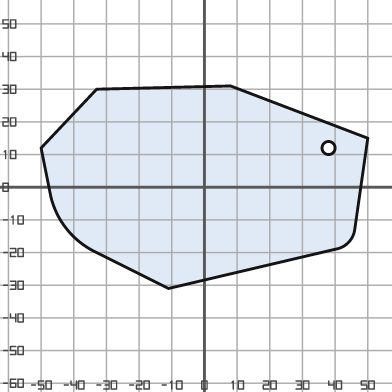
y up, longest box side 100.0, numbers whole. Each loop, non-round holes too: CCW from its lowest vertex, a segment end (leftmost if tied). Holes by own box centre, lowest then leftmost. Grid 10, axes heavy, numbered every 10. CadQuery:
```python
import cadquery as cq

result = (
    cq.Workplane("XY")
    .moveTo(-11.0, -31.0)
    .lineTo(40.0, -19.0)
    .threePointArc((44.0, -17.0), (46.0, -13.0))
    .lineTo(50.0, 15.0)
    .lineTo(8.0, 31.0)
    .lineTo(-33.0, 30.0)
    .lineTo(-50.0, 12.0)
    .lineTo(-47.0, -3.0)
    .threePointArc((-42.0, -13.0), (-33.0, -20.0))
    .close()
    .moveTo(38.0, 12.0)
    .circle(2.0)
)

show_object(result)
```